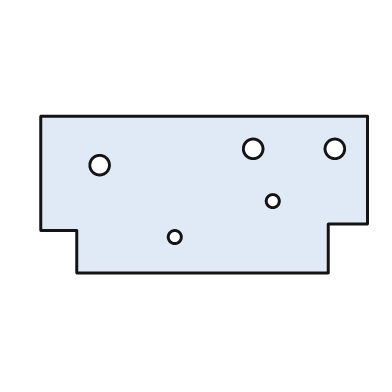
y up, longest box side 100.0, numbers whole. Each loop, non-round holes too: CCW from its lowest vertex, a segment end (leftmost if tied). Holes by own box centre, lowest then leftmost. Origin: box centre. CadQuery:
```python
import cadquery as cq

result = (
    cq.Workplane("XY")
    .moveTo(-39.0, -24.0)
    .lineTo(38.0, -24.0)
    .lineTo(38.0, -9.0)
    .lineTo(50.0, -9.0)
    .lineTo(50.0, 24.0)
    .lineTo(-50.0, 24.0)
    .lineTo(-50.0, -11.0)
    .lineTo(-39.0, -11.0)
    .close()
    .moveTo(-9.0, -13.0)
    .circle(2.0)
    .moveTo(21.0, -2.0)
    .circle(2.0)
    .moveTo(-32.0, 9.0)
    .circle(3.0)
    .moveTo(15.0, 14.0)
    .circle(3.0)
    .moveTo(40.0, 14.0)
    .circle(3.0)
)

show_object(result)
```